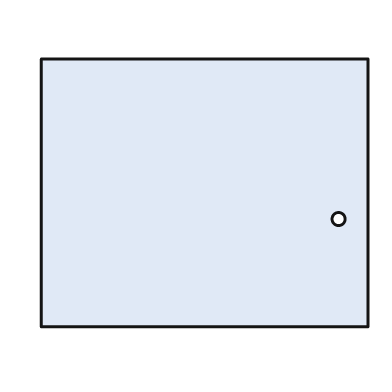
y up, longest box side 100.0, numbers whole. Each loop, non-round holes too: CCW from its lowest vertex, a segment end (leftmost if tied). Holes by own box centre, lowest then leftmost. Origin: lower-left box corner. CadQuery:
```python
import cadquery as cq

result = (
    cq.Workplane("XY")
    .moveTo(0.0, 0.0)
    .lineTo(100.0, 0.0)
    .lineTo(100.0, 82.0)
    .lineTo(0.0, 82.0)
    .close()
    .moveTo(91.0, 33.0)
    .circle(2.0)
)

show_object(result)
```